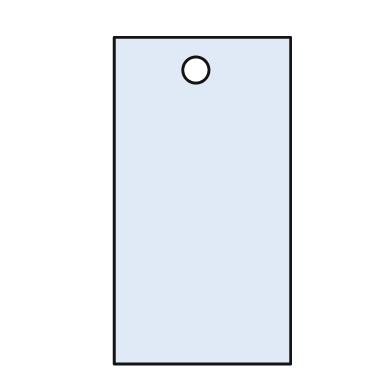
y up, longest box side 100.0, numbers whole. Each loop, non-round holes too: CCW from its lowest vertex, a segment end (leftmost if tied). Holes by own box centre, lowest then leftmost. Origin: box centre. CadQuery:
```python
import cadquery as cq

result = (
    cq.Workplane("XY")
    .moveTo(-27.0, -50.0)
    .lineTo(27.0, -50.0)
    .lineTo(27.0, 50.0)
    .lineTo(-27.0, 50.0)
    .close()
    .moveTo(-2.0, 40.0)
    .circle(4.0)
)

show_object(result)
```